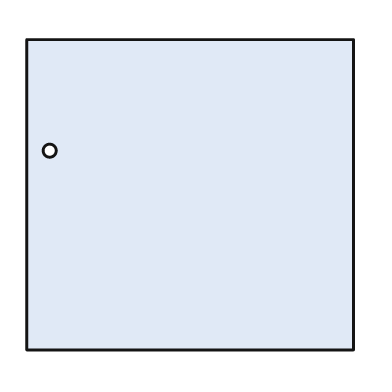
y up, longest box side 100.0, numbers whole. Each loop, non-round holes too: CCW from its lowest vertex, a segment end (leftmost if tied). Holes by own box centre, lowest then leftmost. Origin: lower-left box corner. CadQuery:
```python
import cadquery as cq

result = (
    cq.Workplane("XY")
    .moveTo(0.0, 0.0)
    .lineTo(100.0, 0.0)
    .lineTo(100.0, 95.0)
    .lineTo(0.0, 95.0)
    .close()
    .moveTo(7.0, 61.0)
    .circle(2.0)
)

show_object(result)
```